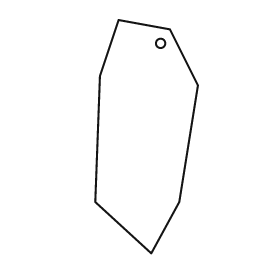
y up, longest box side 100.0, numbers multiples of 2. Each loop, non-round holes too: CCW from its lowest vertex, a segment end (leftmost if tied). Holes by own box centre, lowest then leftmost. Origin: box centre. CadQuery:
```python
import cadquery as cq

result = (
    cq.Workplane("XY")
    .moveTo(2.0, -50.0)
    .lineTo(14.0, -28.0)
    .lineTo(22.0, 22.0)
    .lineTo(10.0, 46.0)
    .lineTo(-12.0, 50.0)
    .lineTo(-20.0, 26.0)
    .lineTo(-22.0, -28.0)
    .close()
    .moveTo(6.0, 40.0)
    .circle(2.0)
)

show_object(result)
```